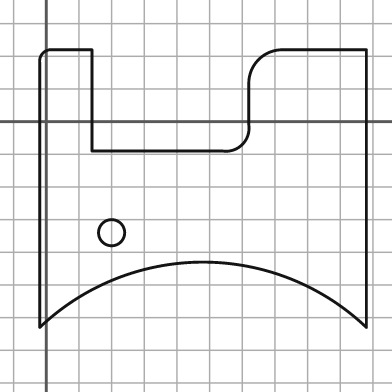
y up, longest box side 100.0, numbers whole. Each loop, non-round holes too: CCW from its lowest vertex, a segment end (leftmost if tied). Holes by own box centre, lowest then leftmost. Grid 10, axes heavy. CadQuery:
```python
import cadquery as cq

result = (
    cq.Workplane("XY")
    .moveTo(-2.0, -63.0)
    .threePointArc((48.0, -43.0), (98.0, -63.0))
    .lineTo(98.0, 22.0)
    .lineTo(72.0, 22.0)
    .threePointArc((65.0, 19.0), (62.0, 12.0))
    .lineTo(62.0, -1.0)
    .threePointArc((60.0, -7.0), (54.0, -9.0))
    .lineTo(14.0, -9.0)
    .lineTo(14.0, 22.0)
    .lineTo(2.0, 22.0)
    .threePointArc((-1.0, 21.0), (-2.0, 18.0))
    .close()
    .moveTo(20.0, -34.0)
    .circle(4.0)
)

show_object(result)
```